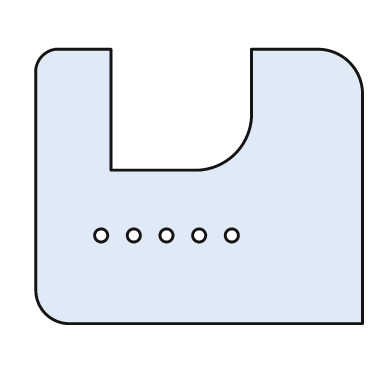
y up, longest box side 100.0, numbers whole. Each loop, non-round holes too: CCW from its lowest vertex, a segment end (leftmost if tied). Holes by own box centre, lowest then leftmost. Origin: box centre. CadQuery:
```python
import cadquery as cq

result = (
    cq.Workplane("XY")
    .moveTo(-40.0, -42.0)
    .lineTo(50.0, -42.0)
    .lineTo(50.0, 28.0)
    .threePointArc((46.0, 38.0), (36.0, 42.0))
    .lineTo(16.0, 42.0)
    .lineTo(16.0, 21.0)
    .threePointArc((11.0, 10.0), (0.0, 5.0))
    .lineTo(-27.0, 5.0)
    .lineTo(-27.0, 42.0)
    .lineTo(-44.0, 42.0)
    .threePointArc((-48.0, 40.0), (-50.0, 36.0))
    .lineTo(-50.0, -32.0)
    .threePointArc((-47.0, -39.0), (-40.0, -42.0))
    .close()
    .moveTo(-30.0, -15.0)
    .circle(2.0)
    .moveTo(-20.0, -15.0)
    .circle(2.0)
    .moveTo(-10.0, -15.0)
    .circle(2.0)
    .moveTo(0.0, -15.0)
    .circle(2.0)
    .moveTo(10.0, -15.0)
    .circle(2.0)
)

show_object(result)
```